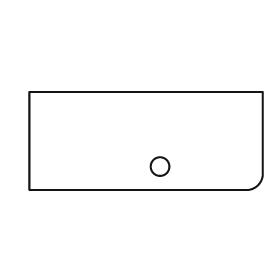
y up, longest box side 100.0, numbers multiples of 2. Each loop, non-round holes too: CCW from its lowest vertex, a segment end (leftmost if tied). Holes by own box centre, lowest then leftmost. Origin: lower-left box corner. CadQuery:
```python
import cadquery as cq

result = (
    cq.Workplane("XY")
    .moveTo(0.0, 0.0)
    .lineTo(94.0, 0.0)
    .threePointArc((98.0, 2.0), (100.0, 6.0))
    .lineTo(100.0, 42.0)
    .lineTo(0.0, 42.0)
    .close()
    .moveTo(56.0, 10.0)
    .circle(4.0)
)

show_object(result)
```